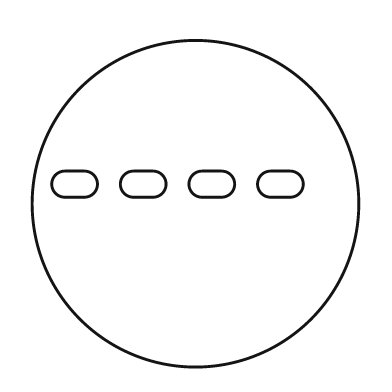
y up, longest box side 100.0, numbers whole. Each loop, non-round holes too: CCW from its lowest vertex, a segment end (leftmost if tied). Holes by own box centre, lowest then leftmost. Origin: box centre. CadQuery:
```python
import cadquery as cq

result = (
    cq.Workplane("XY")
    .moveTo(0.0, 0.0)
    .circle(50.0)
    .moveTo(-40.0, 2.0)
    .lineTo(-34.0, 2.0)
    .threePointArc((-30.0, 6.0), (-34.0, 10.0))
    .lineTo(-40.0, 10.0)
    .threePointArc((-44.0, 6.0), (-40.0, 2.0))
    .close()
    .moveTo(-19.0, 2.0)
    .lineTo(-13.0, 2.0)
    .threePointArc((-9.0, 6.0), (-13.0, 10.0))
    .lineTo(-19.0, 10.0)
    .threePointArc((-23.0, 6.0), (-19.0, 2.0))
    .close()
    .moveTo(2.0, 2.0)
    .lineTo(8.0, 2.0)
    .threePointArc((12.0, 6.0), (8.0, 10.0))
    .lineTo(2.0, 10.0)
    .threePointArc((-2.0, 6.0), (2.0, 2.0))
    .close()
    .moveTo(23.0, 2.0)
    .lineTo(29.0, 2.0)
    .threePointArc((33.0, 6.0), (29.0, 10.0))
    .lineTo(23.0, 10.0)
    .threePointArc((19.0, 6.0), (23.0, 2.0))
    .close()
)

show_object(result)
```